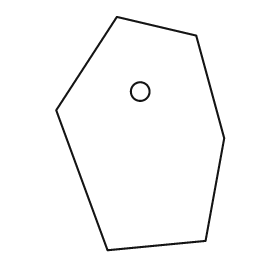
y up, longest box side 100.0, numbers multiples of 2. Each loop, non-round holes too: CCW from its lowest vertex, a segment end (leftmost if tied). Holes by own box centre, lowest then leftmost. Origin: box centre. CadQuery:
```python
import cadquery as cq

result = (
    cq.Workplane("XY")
    .moveTo(-14.0, -50.0)
    .lineTo(28.0, -46.0)
    .lineTo(36.0, -2.0)
    .lineTo(24.0, 42.0)
    .lineTo(-10.0, 50.0)
    .lineTo(-36.0, 10.0)
    .close()
    .moveTo(0.0, 18.0)
    .circle(4.0)
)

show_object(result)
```